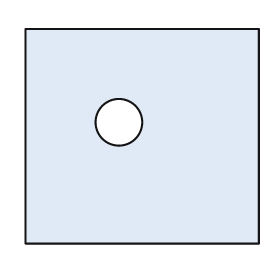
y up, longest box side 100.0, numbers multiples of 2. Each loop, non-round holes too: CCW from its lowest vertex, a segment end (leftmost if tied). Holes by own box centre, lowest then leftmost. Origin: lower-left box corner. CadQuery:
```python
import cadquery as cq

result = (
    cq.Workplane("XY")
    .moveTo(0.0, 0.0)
    .lineTo(100.0, 0.0)
    .lineTo(100.0, 92.0)
    .lineTo(0.0, 92.0)
    .close()
    .moveTo(40.0, 52.0)
    .circle(10.0)
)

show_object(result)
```